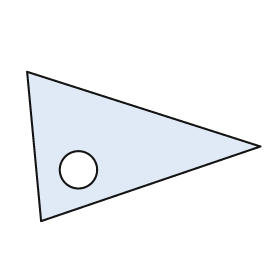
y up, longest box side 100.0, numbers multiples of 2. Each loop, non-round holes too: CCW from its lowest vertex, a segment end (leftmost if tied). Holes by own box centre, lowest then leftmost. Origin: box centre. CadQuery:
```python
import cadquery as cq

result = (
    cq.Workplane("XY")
    .moveTo(-44.0, -32.0)
    .lineTo(50.0, 0.0)
    .lineTo(-50.0, 32.0)
    .close()
    .moveTo(-28.0, -10.0)
    .circle(8.0)
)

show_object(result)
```